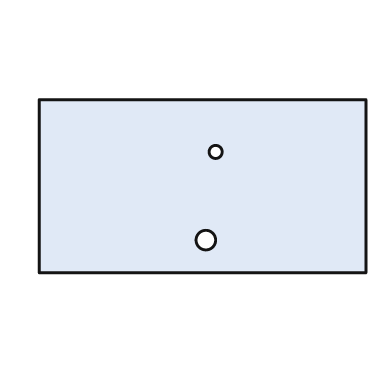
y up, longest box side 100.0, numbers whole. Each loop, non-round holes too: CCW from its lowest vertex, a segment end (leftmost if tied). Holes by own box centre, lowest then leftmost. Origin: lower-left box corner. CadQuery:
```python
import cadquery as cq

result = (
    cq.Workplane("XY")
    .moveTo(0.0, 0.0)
    .lineTo(100.0, 0.0)
    .lineTo(100.0, 53.0)
    .lineTo(0.0, 53.0)
    .close()
    .moveTo(51.0, 10.0)
    .circle(3.0)
    .moveTo(54.0, 37.0)
    .circle(2.0)
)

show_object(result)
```